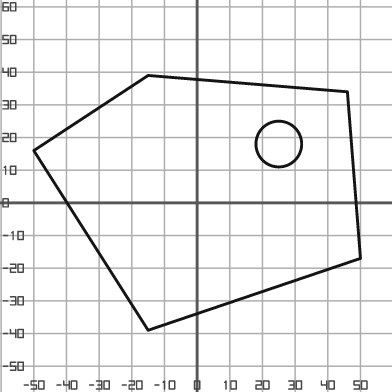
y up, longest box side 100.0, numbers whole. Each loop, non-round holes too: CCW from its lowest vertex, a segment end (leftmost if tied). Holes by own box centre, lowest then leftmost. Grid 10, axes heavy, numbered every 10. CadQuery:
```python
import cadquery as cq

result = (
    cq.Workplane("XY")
    .moveTo(-15.0, -39.0)
    .lineTo(50.0, -17.0)
    .lineTo(46.0, 34.0)
    .lineTo(-15.0, 39.0)
    .lineTo(-50.0, 16.0)
    .close()
    .moveTo(25.0, 18.0)
    .circle(7.0)
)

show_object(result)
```